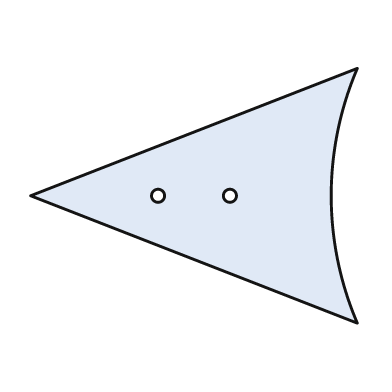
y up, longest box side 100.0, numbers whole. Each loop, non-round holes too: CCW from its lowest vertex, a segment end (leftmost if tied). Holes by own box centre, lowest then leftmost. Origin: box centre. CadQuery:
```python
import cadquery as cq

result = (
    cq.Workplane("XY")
    .moveTo(50.0, -39.0)
    .threePointArc((42.0, 0.0), (50.0, 39.0))
    .lineTo(-50.0, 0.0)
    .close()
    .moveTo(-11.0, 0.0)
    .circle(2.0)
    .moveTo(11.0, 0.0)
    .circle(2.0)
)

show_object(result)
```